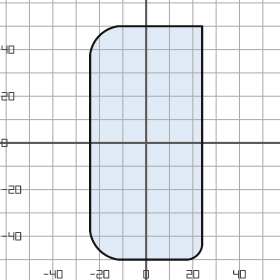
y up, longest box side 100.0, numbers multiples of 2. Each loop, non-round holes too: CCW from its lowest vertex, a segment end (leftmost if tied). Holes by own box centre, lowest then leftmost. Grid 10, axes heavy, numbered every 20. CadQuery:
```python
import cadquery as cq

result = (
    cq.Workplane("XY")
    .moveTo(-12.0, -50.0)
    .lineTo(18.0, -50.0)
    .threePointArc((22.0, -48.0), (24.0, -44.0))
    .lineTo(24.0, 50.0)
    .lineTo(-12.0, 50.0)
    .threePointArc((-20.0, 46.0), (-24.0, 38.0))
    .lineTo(-24.0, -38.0)
    .threePointArc((-20.0, -46.0), (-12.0, -50.0))
    .close()
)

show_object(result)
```